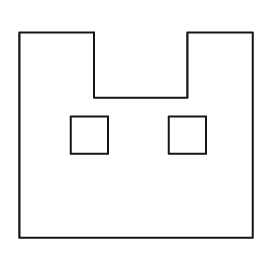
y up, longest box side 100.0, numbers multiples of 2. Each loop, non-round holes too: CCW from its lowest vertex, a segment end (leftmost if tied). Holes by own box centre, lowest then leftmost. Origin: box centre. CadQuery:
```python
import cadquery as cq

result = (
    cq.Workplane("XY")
    .moveTo(-50.0, -44.0)
    .lineTo(50.0, -44.0)
    .lineTo(50.0, 44.0)
    .lineTo(22.0, 44.0)
    .lineTo(22.0, 16.0)
    .lineTo(-18.0, 16.0)
    .lineTo(-18.0, 44.0)
    .lineTo(-50.0, 44.0)
    .close()
    .moveTo(-28.0, -8.0)
    .lineTo(-12.0, -8.0)
    .lineTo(-12.0, 8.0)
    .lineTo(-28.0, 8.0)
    .close()
    .moveTo(14.0, -8.0)
    .lineTo(30.0, -8.0)
    .lineTo(30.0, 8.0)
    .lineTo(14.0, 8.0)
    .close()
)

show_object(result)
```